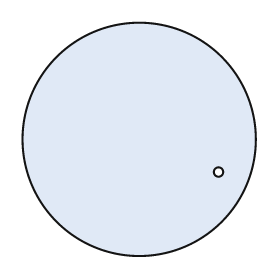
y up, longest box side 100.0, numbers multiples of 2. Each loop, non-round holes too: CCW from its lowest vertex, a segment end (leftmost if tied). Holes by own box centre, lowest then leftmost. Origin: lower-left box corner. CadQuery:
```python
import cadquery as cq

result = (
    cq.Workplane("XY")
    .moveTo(50.0, 50.0)
    .circle(50.0)
    .moveTo(84.0, 36.0)
    .circle(2.0)
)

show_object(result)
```